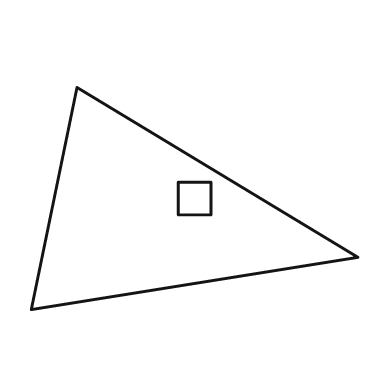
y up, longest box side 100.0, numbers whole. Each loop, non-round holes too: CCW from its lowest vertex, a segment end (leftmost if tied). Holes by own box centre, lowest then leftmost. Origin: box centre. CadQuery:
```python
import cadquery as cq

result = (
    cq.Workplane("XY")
    .moveTo(-50.0, -34.0)
    .lineTo(50.0, -18.0)
    .lineTo(-36.0, 34.0)
    .close()
    .moveTo(-5.0, -5.0)
    .lineTo(5.0, -5.0)
    .lineTo(5.0, 5.0)
    .lineTo(-5.0, 5.0)
    .close()
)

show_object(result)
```